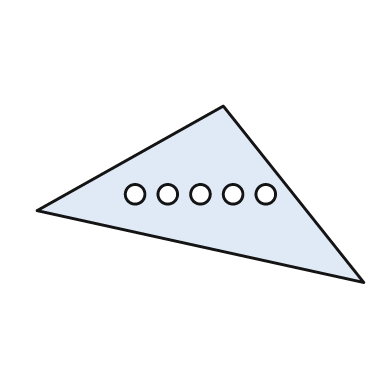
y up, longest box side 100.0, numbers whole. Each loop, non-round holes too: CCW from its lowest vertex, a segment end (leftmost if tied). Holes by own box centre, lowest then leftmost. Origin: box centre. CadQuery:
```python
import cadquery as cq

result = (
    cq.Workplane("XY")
    .moveTo(50.0, -27.0)
    .lineTo(7.0, 27.0)
    .lineTo(-50.0, -5.0)
    .close()
    .moveTo(-20.0, 0.0)
    .circle(3.0)
    .moveTo(-10.0, 0.0)
    .circle(3.0)
    .moveTo(0.0, 0.0)
    .circle(3.0)
    .moveTo(10.0, 0.0)
    .circle(3.0)
    .moveTo(20.0, 0.0)
    .circle(3.0)
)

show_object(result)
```